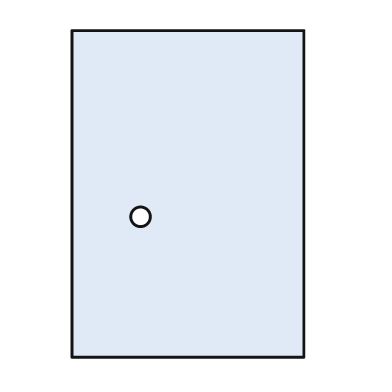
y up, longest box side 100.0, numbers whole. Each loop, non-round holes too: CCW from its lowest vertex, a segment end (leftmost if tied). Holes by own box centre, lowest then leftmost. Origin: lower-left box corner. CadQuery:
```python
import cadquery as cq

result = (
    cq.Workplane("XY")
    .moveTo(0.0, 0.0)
    .lineTo(71.0, 0.0)
    .lineTo(71.0, 100.0)
    .lineTo(0.0, 100.0)
    .close()
    .moveTo(21.0, 43.0)
    .circle(3.0)
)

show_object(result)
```